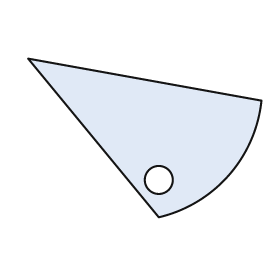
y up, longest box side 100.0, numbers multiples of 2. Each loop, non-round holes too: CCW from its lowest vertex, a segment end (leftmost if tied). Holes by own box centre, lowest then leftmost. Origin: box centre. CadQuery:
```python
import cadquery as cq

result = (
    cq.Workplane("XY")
    .moveTo(6.0, -34.0)
    .threePointArc((36.0, -16.0), (50.0, 16.0))
    .lineTo(-50.0, 34.0)
    .close()
    .moveTo(6.0, -18.0)
    .circle(6.0)
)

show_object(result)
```